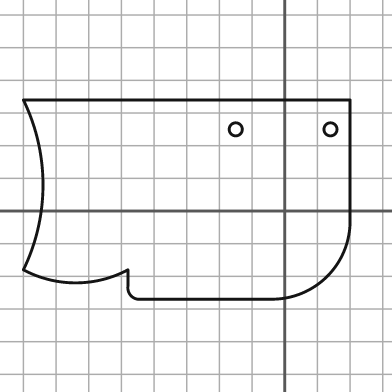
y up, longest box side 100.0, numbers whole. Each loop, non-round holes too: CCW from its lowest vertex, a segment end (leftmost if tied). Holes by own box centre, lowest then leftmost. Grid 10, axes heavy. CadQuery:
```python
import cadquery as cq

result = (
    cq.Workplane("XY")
    .moveTo(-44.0, -27.0)
    .lineTo(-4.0, -27.0)
    .threePointArc((13.0, -20.0), (20.0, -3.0))
    .lineTo(20.0, 34.0)
    .lineTo(-80.0, 34.0)
    .threePointArc((-74.0, 8.0), (-80.0, -18.0))
    .threePointArc((-64.0, -22.0), (-48.0, -18.0))
    .lineTo(-48.0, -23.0)
    .threePointArc((-47.0, -26.0), (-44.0, -27.0))
    .close()
    .moveTo(-15.0, 25.0)
    .circle(2.0)
    .moveTo(14.0, 25.0)
    .circle(2.0)
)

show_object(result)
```